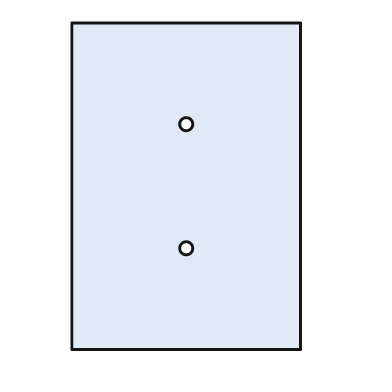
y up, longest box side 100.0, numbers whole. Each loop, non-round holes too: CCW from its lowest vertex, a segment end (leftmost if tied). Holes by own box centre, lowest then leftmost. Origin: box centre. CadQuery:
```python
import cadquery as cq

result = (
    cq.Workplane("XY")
    .moveTo(-35.0, -50.0)
    .lineTo(35.0, -50.0)
    .lineTo(35.0, 50.0)
    .lineTo(-35.0, 50.0)
    .close()
    .moveTo(0.0, -19.0)
    .circle(2.0)
    .moveTo(0.0, 19.0)
    .circle(2.0)
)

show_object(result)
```